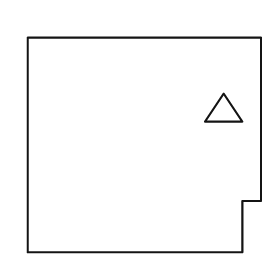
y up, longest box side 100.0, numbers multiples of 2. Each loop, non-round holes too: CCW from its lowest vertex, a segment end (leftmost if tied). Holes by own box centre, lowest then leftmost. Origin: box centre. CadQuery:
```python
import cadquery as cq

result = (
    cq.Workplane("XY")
    .moveTo(-50.0, -46.0)
    .lineTo(42.0, -46.0)
    .lineTo(42.0, -24.0)
    .lineTo(50.0, -24.0)
    .lineTo(50.0, 46.0)
    .lineTo(-50.0, 46.0)
    .close()
    .moveTo(26.0, 10.0)
    .lineTo(42.0, 10.0)
    .lineTo(34.0, 22.0)
    .close()
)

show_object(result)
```